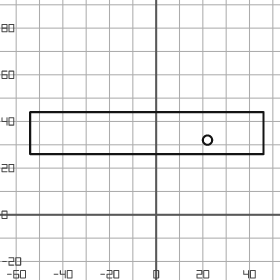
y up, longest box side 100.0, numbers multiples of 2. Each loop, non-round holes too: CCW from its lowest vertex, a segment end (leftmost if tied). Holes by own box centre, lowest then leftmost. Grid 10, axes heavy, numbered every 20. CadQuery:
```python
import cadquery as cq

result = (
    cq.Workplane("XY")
    .moveTo(-54.0, 26.0)
    .lineTo(46.0, 26.0)
    .lineTo(46.0, 44.0)
    .lineTo(-54.0, 44.0)
    .close()
    .moveTo(22.0, 32.0)
    .circle(2.0)
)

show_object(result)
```